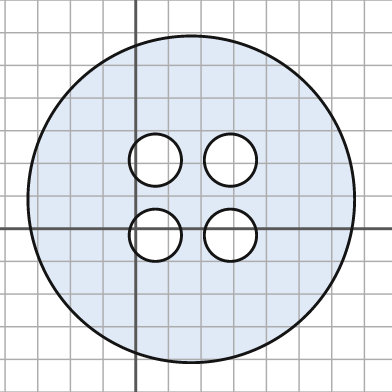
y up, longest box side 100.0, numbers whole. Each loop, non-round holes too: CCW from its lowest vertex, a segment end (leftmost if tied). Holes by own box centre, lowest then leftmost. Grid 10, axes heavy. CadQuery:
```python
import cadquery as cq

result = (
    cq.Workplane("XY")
    .moveTo(17.0, 9.0)
    .circle(50.0)
    .moveTo(6.0, -2.0)
    .circle(8.0)
    .moveTo(29.0, -2.0)
    .circle(8.0)
    .moveTo(6.0, 21.0)
    .circle(8.0)
    .moveTo(29.0, 21.0)
    .circle(8.0)
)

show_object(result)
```